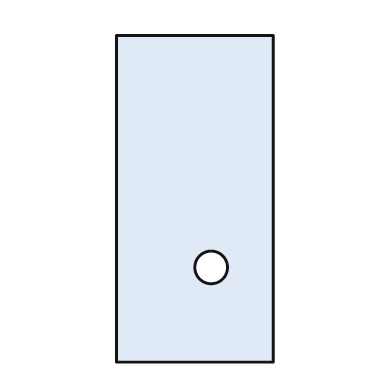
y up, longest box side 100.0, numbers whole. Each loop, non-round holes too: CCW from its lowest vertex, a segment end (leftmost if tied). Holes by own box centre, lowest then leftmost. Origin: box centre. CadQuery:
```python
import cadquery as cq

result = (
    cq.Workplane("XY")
    .moveTo(-24.0, -50.0)
    .lineTo(24.0, -50.0)
    .lineTo(24.0, 50.0)
    .lineTo(-24.0, 50.0)
    .close()
    .moveTo(5.0, -21.0)
    .circle(5.0)
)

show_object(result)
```